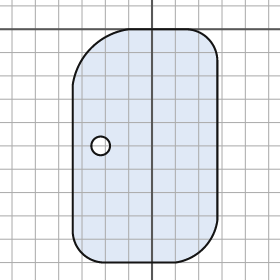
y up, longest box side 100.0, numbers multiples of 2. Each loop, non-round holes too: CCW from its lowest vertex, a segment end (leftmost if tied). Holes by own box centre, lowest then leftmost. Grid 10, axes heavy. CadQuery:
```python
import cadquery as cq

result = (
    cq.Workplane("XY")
    .moveTo(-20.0, -100.0)
    .lineTo(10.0, -100.0)
    .threePointArc((22.0, -94.0), (28.0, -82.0))
    .lineTo(28.0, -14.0)
    .threePointArc((24.0, -4.0), (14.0, 0.0))
    .lineTo(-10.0, 0.0)
    .threePointArc((-26.0, -8.0), (-34.0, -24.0))
    .lineTo(-34.0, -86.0)
    .threePointArc((-30.0, -96.0), (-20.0, -100.0))
    .close()
    .moveTo(-22.0, -50.0)
    .circle(4.0)
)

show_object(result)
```